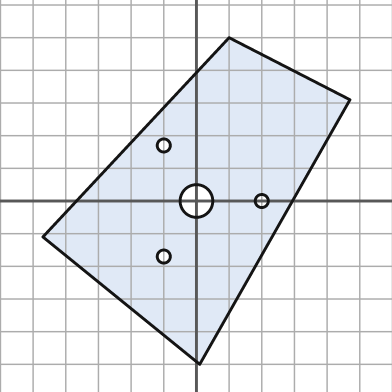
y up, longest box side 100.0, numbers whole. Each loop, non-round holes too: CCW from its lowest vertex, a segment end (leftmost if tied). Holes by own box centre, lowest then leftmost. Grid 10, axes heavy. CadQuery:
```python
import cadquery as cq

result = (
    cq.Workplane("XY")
    .moveTo(1.0, -50.0)
    .lineTo(47.0, 31.0)
    .lineTo(10.0, 50.0)
    .lineTo(-47.0, -11.0)
    .close()
    .moveTo(-10.0, -17.0)
    .circle(2.0)
    .moveTo(0.0, 0.0)
    .circle(5.0)
    .moveTo(20.0, 0.0)
    .circle(2.0)
    .moveTo(-10.0, 17.0)
    .circle(2.0)
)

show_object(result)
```